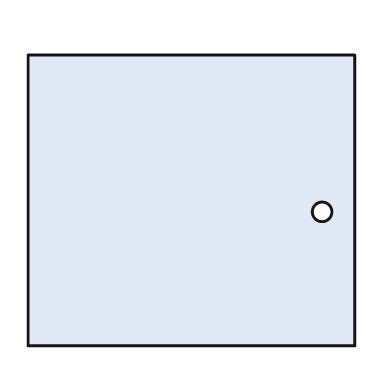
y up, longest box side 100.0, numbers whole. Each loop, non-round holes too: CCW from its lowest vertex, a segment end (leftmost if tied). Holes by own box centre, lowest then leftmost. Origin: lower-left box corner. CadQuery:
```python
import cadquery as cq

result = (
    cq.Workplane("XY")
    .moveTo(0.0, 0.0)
    .lineTo(100.0, 0.0)
    .lineTo(100.0, 89.0)
    .lineTo(0.0, 89.0)
    .close()
    .moveTo(90.0, 41.0)
    .circle(3.0)
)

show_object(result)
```